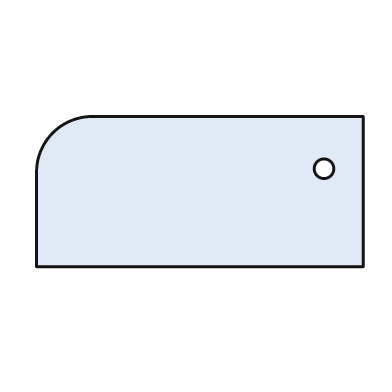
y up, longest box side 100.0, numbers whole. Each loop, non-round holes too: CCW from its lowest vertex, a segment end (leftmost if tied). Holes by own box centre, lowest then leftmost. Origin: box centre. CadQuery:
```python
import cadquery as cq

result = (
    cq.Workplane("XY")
    .moveTo(-50.0, -23.0)
    .lineTo(50.0, -23.0)
    .lineTo(50.0, 23.0)
    .lineTo(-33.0, 23.0)
    .threePointArc((-45.0, 18.0), (-50.0, 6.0))
    .close()
    .moveTo(38.0, 7.0)
    .circle(3.0)
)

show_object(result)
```